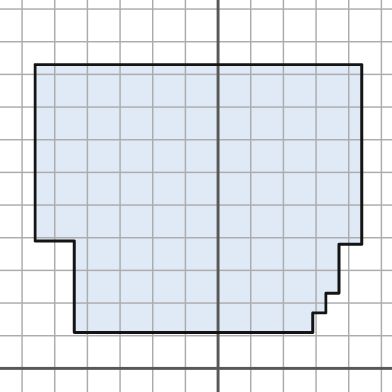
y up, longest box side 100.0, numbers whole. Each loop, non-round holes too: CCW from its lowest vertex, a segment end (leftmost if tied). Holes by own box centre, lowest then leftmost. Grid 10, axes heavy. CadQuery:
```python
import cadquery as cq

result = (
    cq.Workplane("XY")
    .moveTo(-44.0, 11.0)
    .lineTo(29.0, 11.0)
    .lineTo(29.0, 17.0)
    .lineTo(33.0, 17.0)
    .lineTo(33.0, 23.0)
    .lineTo(37.0, 23.0)
    .lineTo(37.0, 38.0)
    .lineTo(44.0, 38.0)
    .lineTo(44.0, 93.0)
    .lineTo(-56.0, 93.0)
    .lineTo(-56.0, 39.0)
    .lineTo(-44.0, 39.0)
    .close()
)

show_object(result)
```